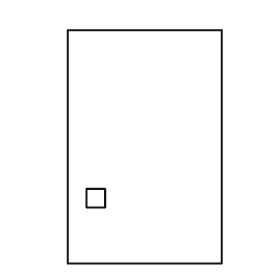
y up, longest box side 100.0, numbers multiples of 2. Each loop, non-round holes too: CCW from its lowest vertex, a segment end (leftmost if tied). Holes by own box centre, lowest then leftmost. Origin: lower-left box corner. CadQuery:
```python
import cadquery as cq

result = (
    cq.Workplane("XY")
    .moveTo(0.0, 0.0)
    .lineTo(66.0, 0.0)
    .lineTo(66.0, 100.0)
    .lineTo(0.0, 100.0)
    .close()
    .moveTo(8.0, 24.0)
    .lineTo(16.0, 24.0)
    .lineTo(16.0, 32.0)
    .lineTo(8.0, 32.0)
    .close()
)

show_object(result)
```